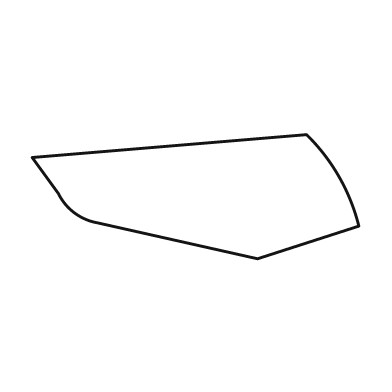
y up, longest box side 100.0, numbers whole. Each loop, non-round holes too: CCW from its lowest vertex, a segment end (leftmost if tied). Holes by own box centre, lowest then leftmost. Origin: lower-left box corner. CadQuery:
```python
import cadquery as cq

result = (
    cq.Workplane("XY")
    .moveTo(69.0, 0.0)
    .lineTo(100.0, 10.0)
    .threePointArc((94.0, 25.0), (84.0, 38.0))
    .lineTo(0.0, 31.0)
    .lineTo(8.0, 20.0)
    .threePointArc((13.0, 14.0), (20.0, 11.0))
    .close()
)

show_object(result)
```